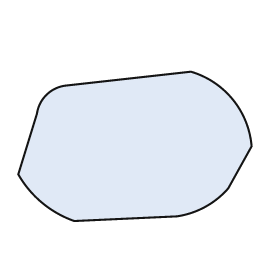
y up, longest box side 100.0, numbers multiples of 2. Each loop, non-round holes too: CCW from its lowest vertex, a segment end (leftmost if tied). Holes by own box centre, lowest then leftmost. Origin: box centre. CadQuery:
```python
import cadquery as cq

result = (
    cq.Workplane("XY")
    .moveTo(-26.0, -32.0)
    .lineTo(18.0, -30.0)
    .threePointArc((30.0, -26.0), (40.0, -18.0))
    .lineTo(50.0, 0.0)
    .threePointArc((42.0, 20.0), (24.0, 32.0))
    .lineTo(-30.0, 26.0)
    .threePointArc((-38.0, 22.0), (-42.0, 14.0))
    .lineTo(-50.0, -12.0)
    .threePointArc((-40.0, -24.0), (-26.0, -32.0))
    .close()
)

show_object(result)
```